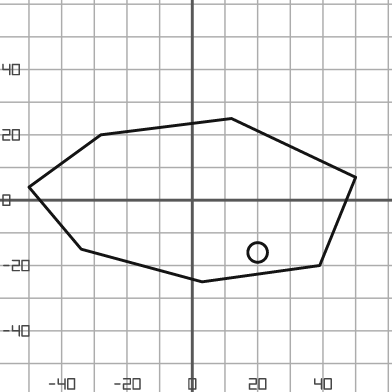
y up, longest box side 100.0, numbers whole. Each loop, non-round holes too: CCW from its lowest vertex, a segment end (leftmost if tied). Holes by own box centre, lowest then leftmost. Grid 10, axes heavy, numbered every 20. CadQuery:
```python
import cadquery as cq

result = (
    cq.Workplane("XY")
    .moveTo(3.0, -25.0)
    .lineTo(39.0, -20.0)
    .lineTo(50.0, 7.0)
    .lineTo(12.0, 25.0)
    .lineTo(-28.0, 20.0)
    .lineTo(-50.0, 4.0)
    .lineTo(-34.0, -15.0)
    .close()
    .moveTo(20.0, -16.0)
    .circle(3.0)
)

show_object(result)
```